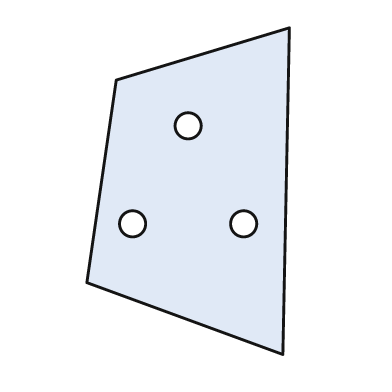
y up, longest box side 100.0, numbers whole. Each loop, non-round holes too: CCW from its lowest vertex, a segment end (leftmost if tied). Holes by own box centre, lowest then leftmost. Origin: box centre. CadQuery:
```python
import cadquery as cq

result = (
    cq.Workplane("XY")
    .moveTo(29.0, -50.0)
    .lineTo(31.0, 50.0)
    .lineTo(-22.0, 34.0)
    .lineTo(-31.0, -28.0)
    .close()
    .moveTo(-17.0, -10.0)
    .circle(4.0)
    .moveTo(17.0, -10.0)
    .circle(4.0)
    .moveTo(0.0, 20.0)
    .circle(4.0)
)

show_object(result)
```